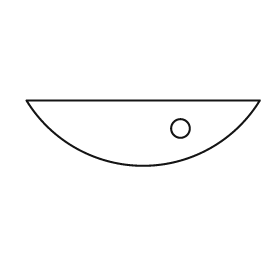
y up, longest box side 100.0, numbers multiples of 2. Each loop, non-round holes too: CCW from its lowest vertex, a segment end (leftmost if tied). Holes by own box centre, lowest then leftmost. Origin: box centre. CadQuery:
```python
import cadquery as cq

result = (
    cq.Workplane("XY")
    .moveTo(-50.0, 14.0)
    .threePointArc((0.0, -14.0), (50.0, 14.0))
    .close()
    .moveTo(16.0, 2.0)
    .circle(4.0)
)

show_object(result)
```